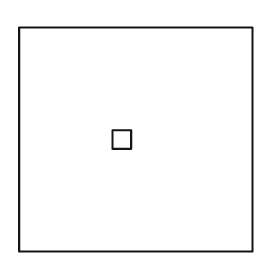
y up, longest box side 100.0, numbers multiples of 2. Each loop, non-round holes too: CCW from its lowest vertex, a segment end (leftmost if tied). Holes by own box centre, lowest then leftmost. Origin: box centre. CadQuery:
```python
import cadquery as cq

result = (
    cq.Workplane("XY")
    .moveTo(-50.0, -48.0)
    .lineTo(50.0, -48.0)
    .lineTo(50.0, 48.0)
    .lineTo(-50.0, 48.0)
    .close()
    .moveTo(-10.0, -4.0)
    .lineTo(-2.0, -4.0)
    .lineTo(-2.0, 4.0)
    .lineTo(-10.0, 4.0)
    .close()
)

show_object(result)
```